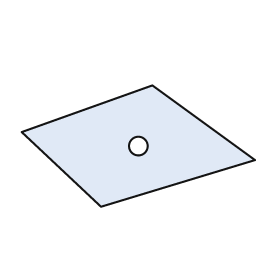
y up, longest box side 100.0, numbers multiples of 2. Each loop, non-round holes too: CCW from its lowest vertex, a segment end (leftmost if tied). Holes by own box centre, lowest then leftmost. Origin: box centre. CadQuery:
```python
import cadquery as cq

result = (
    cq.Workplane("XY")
    .moveTo(-16.0, -26.0)
    .lineTo(50.0, -6.0)
    .lineTo(6.0, 26.0)
    .lineTo(-50.0, 6.0)
    .close()
    .moveTo(0.0, 0.0)
    .circle(4.0)
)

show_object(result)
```